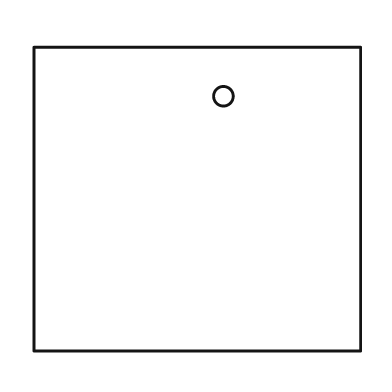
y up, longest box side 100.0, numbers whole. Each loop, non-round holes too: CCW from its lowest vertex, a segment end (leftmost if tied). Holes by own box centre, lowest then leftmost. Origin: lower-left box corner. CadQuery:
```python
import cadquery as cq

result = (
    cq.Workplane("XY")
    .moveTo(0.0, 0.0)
    .lineTo(100.0, 0.0)
    .lineTo(100.0, 93.0)
    .lineTo(0.0, 93.0)
    .close()
    .moveTo(58.0, 78.0)
    .circle(3.0)
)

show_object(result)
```